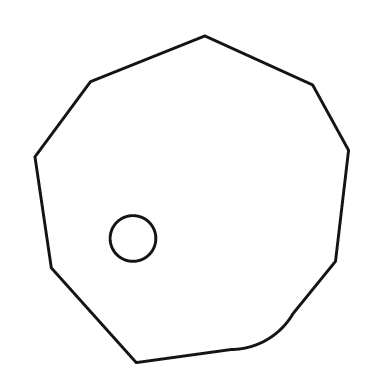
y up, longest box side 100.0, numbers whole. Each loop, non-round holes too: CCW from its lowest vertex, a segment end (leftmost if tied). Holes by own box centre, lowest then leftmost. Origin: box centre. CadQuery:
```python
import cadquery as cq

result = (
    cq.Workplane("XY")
    .moveTo(-17.0, -50.0)
    .lineTo(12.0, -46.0)
    .threePointArc((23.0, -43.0), (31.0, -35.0))
    .lineTo(44.0, -19.0)
    .lineTo(48.0, 15.0)
    .lineTo(37.0, 35.0)
    .lineTo(4.0, 50.0)
    .lineTo(-31.0, 36.0)
    .lineTo(-48.0, 13.0)
    .lineTo(-43.0, -21.0)
    .close()
    .moveTo(-18.0, -12.0)
    .circle(7.0)
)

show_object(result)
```